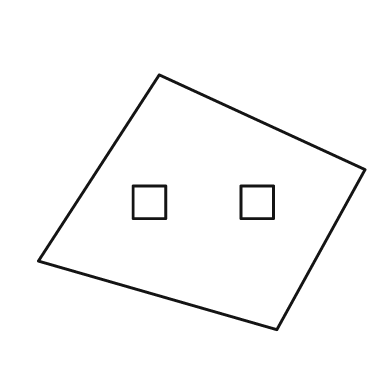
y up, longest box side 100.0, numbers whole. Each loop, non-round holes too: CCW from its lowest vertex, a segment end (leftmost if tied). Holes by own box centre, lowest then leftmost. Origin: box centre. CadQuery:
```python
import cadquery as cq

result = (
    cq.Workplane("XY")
    .moveTo(23.0, -39.0)
    .lineTo(50.0, 10.0)
    .lineTo(-13.0, 39.0)
    .lineTo(-50.0, -18.0)
    .close()
    .moveTo(-21.0, -5.0)
    .lineTo(-11.0, -5.0)
    .lineTo(-11.0, 5.0)
    .lineTo(-21.0, 5.0)
    .close()
    .moveTo(12.0, -5.0)
    .lineTo(22.0, -5.0)
    .lineTo(22.0, 5.0)
    .lineTo(12.0, 5.0)
    .close()
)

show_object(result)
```